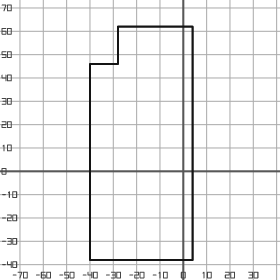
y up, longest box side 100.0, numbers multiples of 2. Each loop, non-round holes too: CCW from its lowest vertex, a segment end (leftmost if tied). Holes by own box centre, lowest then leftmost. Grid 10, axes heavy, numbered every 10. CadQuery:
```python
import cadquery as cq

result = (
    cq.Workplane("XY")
    .moveTo(-40.0, -38.0)
    .lineTo(4.0, -38.0)
    .lineTo(4.0, 62.0)
    .lineTo(-28.0, 62.0)
    .lineTo(-28.0, 46.0)
    .lineTo(-40.0, 46.0)
    .close()
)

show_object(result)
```